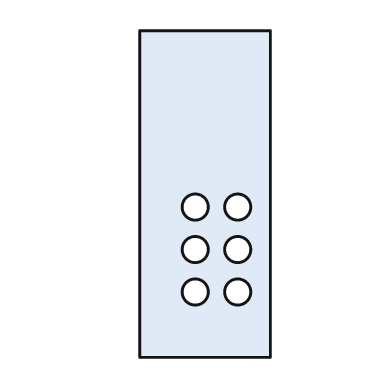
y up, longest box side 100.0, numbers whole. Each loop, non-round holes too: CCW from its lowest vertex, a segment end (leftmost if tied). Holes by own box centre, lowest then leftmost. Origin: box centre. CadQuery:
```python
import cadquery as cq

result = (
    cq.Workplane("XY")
    .moveTo(-20.0, -50.0)
    .lineTo(20.0, -50.0)
    .lineTo(20.0, 50.0)
    .lineTo(-20.0, 50.0)
    .close()
    .moveTo(-3.0, -30.0)
    .circle(4.0)
    .moveTo(10.0, -30.0)
    .circle(4.0)
    .moveTo(-3.0, -17.0)
    .circle(4.0)
    .moveTo(10.0, -17.0)
    .circle(4.0)
    .moveTo(-3.0, -4.0)
    .circle(4.0)
    .moveTo(10.0, -4.0)
    .circle(4.0)
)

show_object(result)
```